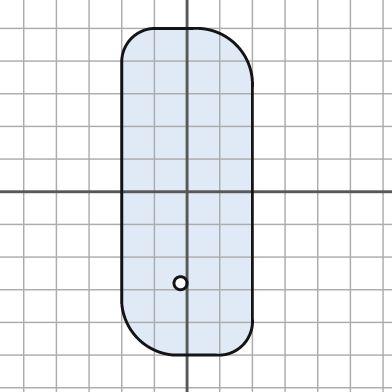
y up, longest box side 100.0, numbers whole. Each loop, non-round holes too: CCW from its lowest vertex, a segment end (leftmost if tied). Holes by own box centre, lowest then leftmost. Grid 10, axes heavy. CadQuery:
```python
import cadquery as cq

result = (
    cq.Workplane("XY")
    .moveTo(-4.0, -50.0)
    .lineTo(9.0, -50.0)
    .threePointArc((17.0, -47.0), (20.0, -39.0))
    .lineTo(20.0, 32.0)
    .threePointArc((15.0, 45.0), (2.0, 50.0))
    .lineTo(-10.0, 50.0)
    .threePointArc((-17.0, 47.0), (-20.0, 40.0))
    .lineTo(-20.0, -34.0)
    .threePointArc((-15.0, -45.0), (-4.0, -50.0))
    .close()
    .moveTo(-2.0, -28.0)
    .circle(2.0)
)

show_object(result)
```